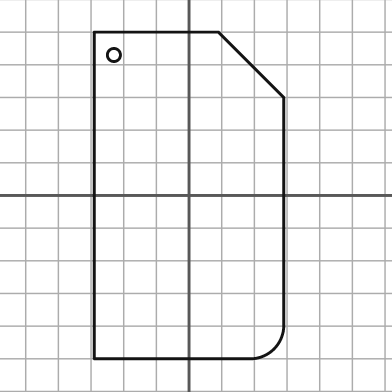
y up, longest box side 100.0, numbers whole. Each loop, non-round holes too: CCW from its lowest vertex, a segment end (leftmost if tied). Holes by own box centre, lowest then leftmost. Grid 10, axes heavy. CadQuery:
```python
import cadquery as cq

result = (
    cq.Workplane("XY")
    .moveTo(-29.0, -50.0)
    .lineTo(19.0, -50.0)
    .threePointArc((26.0, -47.0), (29.0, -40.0))
    .lineTo(29.0, 30.0)
    .lineTo(9.0, 50.0)
    .lineTo(-29.0, 50.0)
    .close()
    .moveTo(-23.0, 43.0)
    .circle(2.0)
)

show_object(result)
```